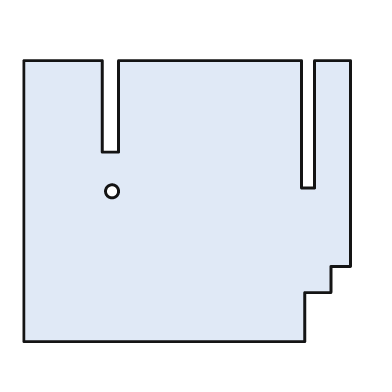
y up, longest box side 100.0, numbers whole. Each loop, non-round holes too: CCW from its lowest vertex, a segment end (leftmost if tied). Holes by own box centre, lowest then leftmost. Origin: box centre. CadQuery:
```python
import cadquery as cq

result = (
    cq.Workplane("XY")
    .moveTo(-50.0, -43.0)
    .lineTo(36.0, -43.0)
    .lineTo(36.0, -28.0)
    .lineTo(44.0, -28.0)
    .lineTo(44.0, -20.0)
    .lineTo(50.0, -20.0)
    .lineTo(50.0, 43.0)
    .lineTo(39.0, 43.0)
    .lineTo(39.0, 4.0)
    .lineTo(35.0, 4.0)
    .lineTo(35.0, 43.0)
    .lineTo(-21.0, 43.0)
    .lineTo(-21.0, 15.0)
    .lineTo(-26.0, 15.0)
    .lineTo(-26.0, 43.0)
    .lineTo(-50.0, 43.0)
    .close()
    .moveTo(-23.0, 3.0)
    .circle(2.0)
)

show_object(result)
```